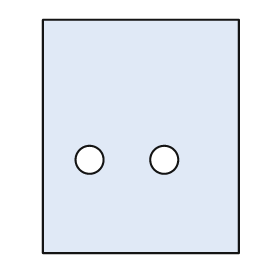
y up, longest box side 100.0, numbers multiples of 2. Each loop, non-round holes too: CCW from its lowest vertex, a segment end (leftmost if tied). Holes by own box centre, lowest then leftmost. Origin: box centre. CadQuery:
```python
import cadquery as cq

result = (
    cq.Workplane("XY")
    .moveTo(-42.0, -50.0)
    .lineTo(42.0, -50.0)
    .lineTo(42.0, 50.0)
    .lineTo(-42.0, 50.0)
    .close()
    .moveTo(-22.0, -10.0)
    .circle(6.0)
    .moveTo(10.0, -10.0)
    .circle(6.0)
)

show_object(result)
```